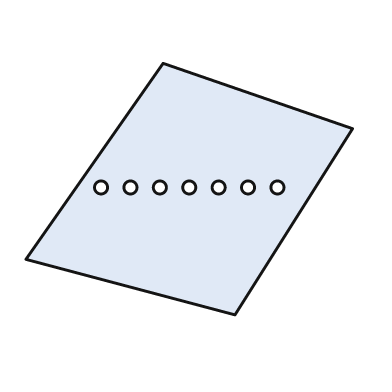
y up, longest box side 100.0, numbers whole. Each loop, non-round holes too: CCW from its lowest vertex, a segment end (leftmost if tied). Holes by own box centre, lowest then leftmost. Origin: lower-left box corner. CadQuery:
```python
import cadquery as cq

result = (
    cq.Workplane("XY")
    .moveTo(64.0, 0.0)
    .lineTo(100.0, 57.0)
    .lineTo(42.0, 77.0)
    .lineTo(0.0, 17.0)
    .close()
    .moveTo(23.0, 39.0)
    .circle(2.0)
    .moveTo(32.0, 39.0)
    .circle(2.0)
    .moveTo(41.0, 39.0)
    .circle(2.0)
    .moveTo(50.0, 39.0)
    .circle(2.0)
    .moveTo(59.0, 39.0)
    .circle(2.0)
    .moveTo(68.0, 39.0)
    .circle(2.0)
    .moveTo(77.0, 39.0)
    .circle(2.0)
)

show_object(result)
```